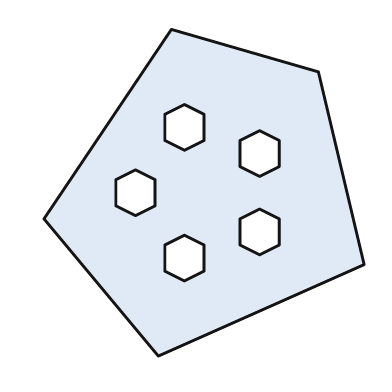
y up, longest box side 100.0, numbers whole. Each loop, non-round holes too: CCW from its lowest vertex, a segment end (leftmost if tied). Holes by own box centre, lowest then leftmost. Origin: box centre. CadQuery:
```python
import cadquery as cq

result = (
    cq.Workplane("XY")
    .moveTo(-14.0, -50.0)
    .lineTo(49.0, -22.0)
    .lineTo(35.0, 37.0)
    .lineTo(-10.0, 50.0)
    .lineTo(-49.0, -8.0)
    .close()
    .moveTo(-6.0, -27.0)
    .lineTo(0.0, -24.0)
    .lineTo(0.0, -16.0)
    .lineTo(-6.0, -13.0)
    .lineTo(-12.0, -16.0)
    .lineTo(-12.0, -24.0)
    .close()
    .moveTo(17.0, -19.0)
    .lineTo(23.0, -16.0)
    .lineTo(23.0, -8.0)
    .lineTo(17.0, -5.0)
    .lineTo(11.0, -8.0)
    .lineTo(11.0, -16.0)
    .close()
    .moveTo(-21.0, -7.0)
    .lineTo(-15.0, -4.0)
    .lineTo(-15.0, 4.0)
    .lineTo(-21.0, 7.0)
    .lineTo(-27.0, 4.0)
    .lineTo(-27.0, -4.0)
    .close()
    .moveTo(17.0, 5.0)
    .lineTo(23.0, 8.0)
    .lineTo(23.0, 16.0)
    .lineTo(17.0, 19.0)
    .lineTo(11.0, 16.0)
    .lineTo(11.0, 8.0)
    .close()
    .moveTo(-6.0, 13.0)
    .lineTo(0.0, 16.0)
    .lineTo(0.0, 24.0)
    .lineTo(-6.0, 27.0)
    .lineTo(-12.0, 24.0)
    .lineTo(-12.0, 16.0)
    .close()
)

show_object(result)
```